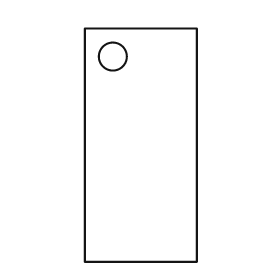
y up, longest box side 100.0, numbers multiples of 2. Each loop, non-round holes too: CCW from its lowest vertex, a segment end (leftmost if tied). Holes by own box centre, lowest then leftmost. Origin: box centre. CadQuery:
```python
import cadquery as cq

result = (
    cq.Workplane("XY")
    .moveTo(-24.0, -50.0)
    .lineTo(24.0, -50.0)
    .lineTo(24.0, 50.0)
    .lineTo(-24.0, 50.0)
    .close()
    .moveTo(-12.0, 38.0)
    .circle(6.0)
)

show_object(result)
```